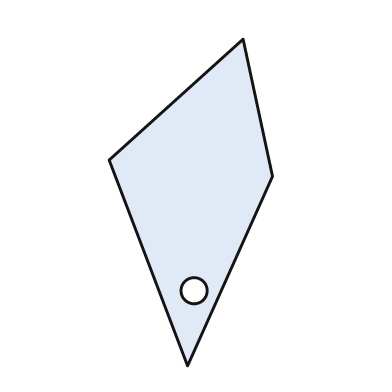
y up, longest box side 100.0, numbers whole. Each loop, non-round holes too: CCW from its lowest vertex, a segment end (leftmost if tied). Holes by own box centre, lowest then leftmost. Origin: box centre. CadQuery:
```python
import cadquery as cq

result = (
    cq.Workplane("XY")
    .moveTo(-1.0, -50.0)
    .lineTo(25.0, 8.0)
    .lineTo(16.0, 50.0)
    .lineTo(-25.0, 13.0)
    .close()
    .moveTo(1.0, -27.0)
    .circle(4.0)
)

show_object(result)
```